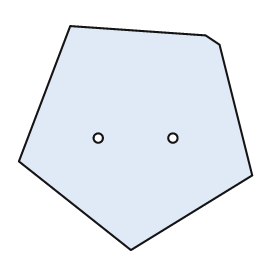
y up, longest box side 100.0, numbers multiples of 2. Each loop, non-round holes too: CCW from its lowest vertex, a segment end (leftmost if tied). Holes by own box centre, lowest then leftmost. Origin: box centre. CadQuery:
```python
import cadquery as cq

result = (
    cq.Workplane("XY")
    .moveTo(-2.0, -48.0)
    .lineTo(50.0, -16.0)
    .lineTo(36.0, 40.0)
    .lineTo(30.0, 44.0)
    .lineTo(-28.0, 48.0)
    .lineTo(-50.0, -10.0)
    .close()
    .moveTo(-16.0, 0.0)
    .circle(2.0)
    .moveTo(16.0, 0.0)
    .circle(2.0)
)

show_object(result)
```